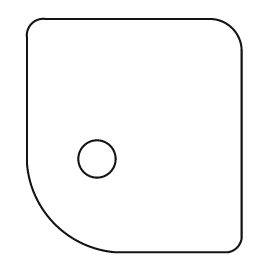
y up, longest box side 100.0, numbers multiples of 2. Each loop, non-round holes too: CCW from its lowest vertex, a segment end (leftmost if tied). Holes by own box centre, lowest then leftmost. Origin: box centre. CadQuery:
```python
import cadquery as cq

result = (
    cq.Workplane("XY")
    .moveTo(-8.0, -50.0)
    .lineTo(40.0, -50.0)
    .threePointArc((44.0, -48.0), (46.0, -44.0))
    .lineTo(46.0, 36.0)
    .threePointArc((42.0, 46.0), (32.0, 50.0))
    .lineTo(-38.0, 50.0)
    .threePointArc((-44.0, 48.0), (-46.0, 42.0))
    .lineTo(-46.0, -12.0)
    .threePointArc((-34.0, -38.0), (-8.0, -50.0))
    .close()
    .moveTo(-16.0, -10.0)
    .circle(8.0)
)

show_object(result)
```